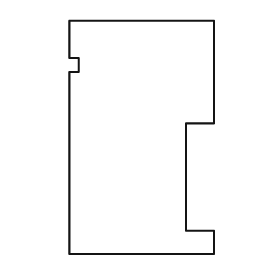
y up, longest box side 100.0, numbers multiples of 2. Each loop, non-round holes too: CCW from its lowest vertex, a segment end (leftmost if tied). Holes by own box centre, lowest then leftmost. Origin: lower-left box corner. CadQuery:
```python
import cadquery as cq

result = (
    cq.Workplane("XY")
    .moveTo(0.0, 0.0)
    .lineTo(62.0, 0.0)
    .lineTo(62.0, 10.0)
    .lineTo(50.0, 10.0)
    .lineTo(50.0, 56.0)
    .lineTo(62.0, 56.0)
    .lineTo(62.0, 100.0)
    .lineTo(0.0, 100.0)
    .lineTo(0.0, 84.0)
    .lineTo(4.0, 84.0)
    .lineTo(4.0, 78.0)
    .lineTo(0.0, 78.0)
    .close()
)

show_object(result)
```